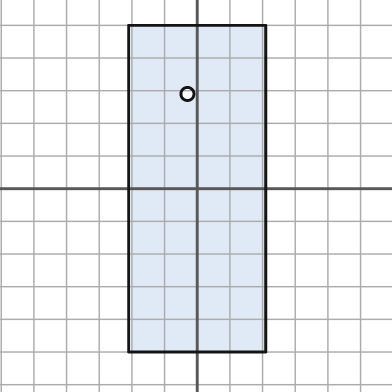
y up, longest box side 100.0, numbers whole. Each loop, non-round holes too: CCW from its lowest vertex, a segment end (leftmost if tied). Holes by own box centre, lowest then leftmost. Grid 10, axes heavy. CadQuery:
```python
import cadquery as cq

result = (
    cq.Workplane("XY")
    .moveTo(-21.0, -50.0)
    .lineTo(21.0, -50.0)
    .lineTo(21.0, 50.0)
    .lineTo(-21.0, 50.0)
    .close()
    .moveTo(-3.0, 29.0)
    .circle(2.0)
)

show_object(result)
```